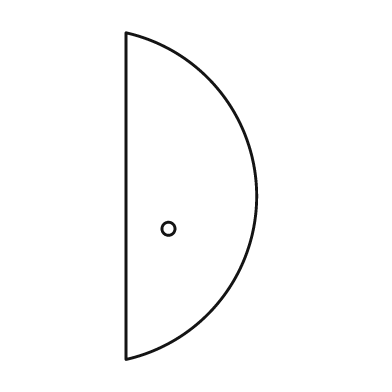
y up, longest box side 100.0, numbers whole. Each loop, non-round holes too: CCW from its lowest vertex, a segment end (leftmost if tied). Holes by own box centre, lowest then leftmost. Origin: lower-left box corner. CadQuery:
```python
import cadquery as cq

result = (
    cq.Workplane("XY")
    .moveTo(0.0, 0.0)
    .threePointArc((40.0, 50.0), (0.0, 100.0))
    .close()
    .moveTo(13.0, 40.0)
    .circle(2.0)
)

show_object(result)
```